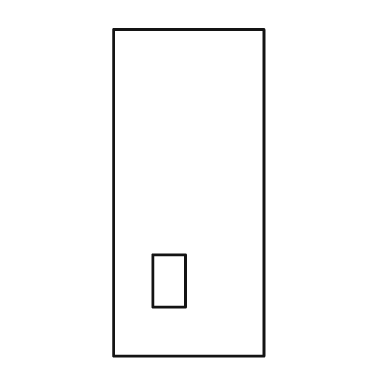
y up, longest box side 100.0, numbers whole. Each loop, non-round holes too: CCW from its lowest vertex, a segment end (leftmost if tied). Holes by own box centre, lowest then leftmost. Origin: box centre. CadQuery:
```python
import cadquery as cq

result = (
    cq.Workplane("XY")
    .moveTo(-23.0, -50.0)
    .lineTo(23.0, -50.0)
    .lineTo(23.0, 50.0)
    .lineTo(-23.0, 50.0)
    .close()
    .moveTo(-11.0, -35.0)
    .lineTo(-1.0, -35.0)
    .lineTo(-1.0, -19.0)
    .lineTo(-11.0, -19.0)
    .close()
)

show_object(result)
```